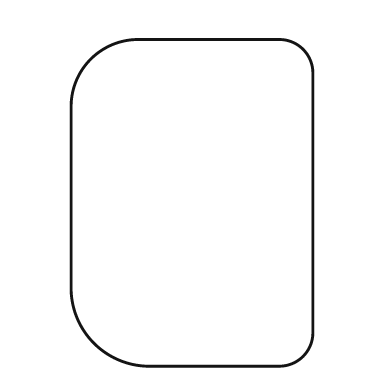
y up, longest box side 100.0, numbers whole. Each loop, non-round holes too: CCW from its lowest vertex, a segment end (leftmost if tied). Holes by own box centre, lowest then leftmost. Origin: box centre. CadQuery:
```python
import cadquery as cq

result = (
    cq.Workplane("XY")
    .moveTo(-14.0, -50.0)
    .lineTo(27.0, -50.0)
    .threePointArc((34.0, -47.0), (37.0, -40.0))
    .lineTo(37.0, 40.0)
    .threePointArc((34.0, 47.0), (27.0, 50.0))
    .lineTo(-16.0, 50.0)
    .threePointArc((-31.0, 44.0), (-37.0, 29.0))
    .lineTo(-37.0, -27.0)
    .threePointArc((-30.0, -43.0), (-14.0, -50.0))
    .close()
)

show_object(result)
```